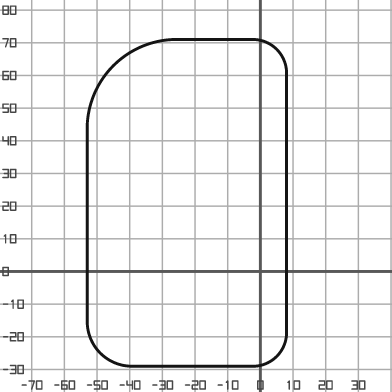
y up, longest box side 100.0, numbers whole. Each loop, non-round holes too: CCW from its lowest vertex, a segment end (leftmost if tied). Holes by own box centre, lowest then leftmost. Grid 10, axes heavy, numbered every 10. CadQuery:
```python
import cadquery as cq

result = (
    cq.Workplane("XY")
    .moveTo(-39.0, -29.0)
    .lineTo(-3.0, -29.0)
    .threePointArc((5.0, -26.0), (8.0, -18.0))
    .lineTo(8.0, 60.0)
    .threePointArc((5.0, 68.0), (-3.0, 71.0))
    .lineTo(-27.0, 71.0)
    .threePointArc((-45.0, 63.0), (-53.0, 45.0))
    .lineTo(-53.0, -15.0)
    .threePointArc((-49.0, -25.0), (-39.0, -29.0))
    .close()
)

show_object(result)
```